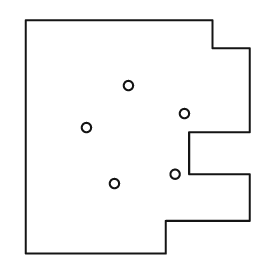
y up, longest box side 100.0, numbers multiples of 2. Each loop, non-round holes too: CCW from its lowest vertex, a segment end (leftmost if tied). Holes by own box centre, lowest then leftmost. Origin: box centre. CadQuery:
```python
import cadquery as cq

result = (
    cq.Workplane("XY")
    .moveTo(-48.0, -50.0)
    .lineTo(12.0, -50.0)
    .lineTo(12.0, -36.0)
    .lineTo(48.0, -36.0)
    .lineTo(48.0, -16.0)
    .lineTo(22.0, -16.0)
    .lineTo(22.0, 2.0)
    .lineTo(48.0, 2.0)
    .lineTo(48.0, 38.0)
    .lineTo(32.0, 38.0)
    .lineTo(32.0, 50.0)
    .lineTo(-48.0, 50.0)
    .close()
    .moveTo(-10.0, -20.0)
    .circle(2.0)
    .moveTo(16.0, -16.0)
    .circle(2.0)
    .moveTo(-22.0, 4.0)
    .circle(2.0)
    .moveTo(20.0, 10.0)
    .circle(2.0)
    .moveTo(-4.0, 22.0)
    .circle(2.0)
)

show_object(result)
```